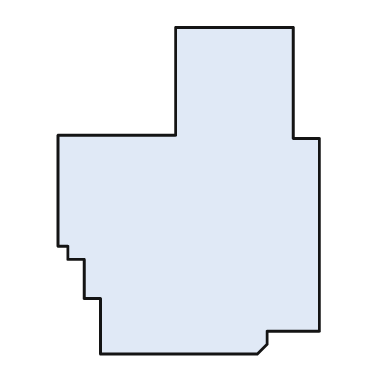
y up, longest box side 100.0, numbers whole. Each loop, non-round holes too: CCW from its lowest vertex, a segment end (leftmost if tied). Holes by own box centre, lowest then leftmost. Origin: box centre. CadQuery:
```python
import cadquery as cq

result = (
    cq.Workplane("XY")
    .moveTo(-27.0, -50.0)
    .lineTo(21.0, -50.0)
    .lineTo(24.0, -47.0)
    .lineTo(24.0, -43.0)
    .lineTo(40.0, -43.0)
    .lineTo(40.0, 16.0)
    .lineTo(32.0, 16.0)
    .lineTo(32.0, 50.0)
    .lineTo(-4.0, 50.0)
    .lineTo(-4.0, 17.0)
    .lineTo(-40.0, 17.0)
    .lineTo(-40.0, -17.0)
    .lineTo(-37.0, -17.0)
    .lineTo(-37.0, -21.0)
    .lineTo(-32.0, -21.0)
    .lineTo(-32.0, -33.0)
    .lineTo(-27.0, -33.0)
    .close()
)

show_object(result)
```